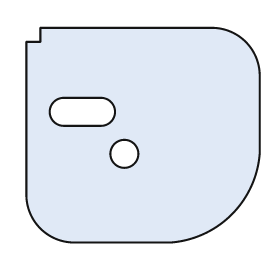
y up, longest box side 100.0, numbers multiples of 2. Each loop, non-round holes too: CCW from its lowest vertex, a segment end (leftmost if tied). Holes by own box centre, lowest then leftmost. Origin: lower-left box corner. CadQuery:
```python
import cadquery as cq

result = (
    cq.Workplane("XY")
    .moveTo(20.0, 0.0)
    .lineTo(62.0, 0.0)
    .threePointArc((88.0, 12.0), (100.0, 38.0))
    .lineTo(100.0, 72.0)
    .threePointArc((94.0, 86.0), (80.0, 92.0))
    .lineTo(6.0, 92.0)
    .lineTo(6.0, 86.0)
    .lineTo(0.0, 86.0)
    .lineTo(0.0, 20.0)
    .threePointArc((6.0, 6.0), (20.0, 0.0))
    .close()
    .moveTo(42.0, 38.0)
    .circle(6.0)
    .moveTo(16.0, 50.0)
    .lineTo(32.0, 50.0)
    .threePointArc((38.0, 56.0), (32.0, 62.0))
    .lineTo(16.0, 62.0)
    .threePointArc((10.0, 56.0), (16.0, 50.0))
    .close()
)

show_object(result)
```